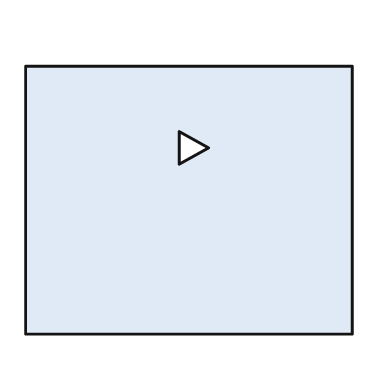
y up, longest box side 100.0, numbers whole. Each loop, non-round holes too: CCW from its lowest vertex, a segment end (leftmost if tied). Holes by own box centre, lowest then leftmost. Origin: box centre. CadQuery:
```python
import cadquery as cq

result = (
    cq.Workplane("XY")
    .moveTo(-50.0, -41.0)
    .lineTo(50.0, -41.0)
    .lineTo(50.0, 41.0)
    .lineTo(-50.0, 41.0)
    .close()
    .moveTo(-3.0, 11.0)
    .lineTo(6.0, 16.0)
    .lineTo(-3.0, 21.0)
    .close()
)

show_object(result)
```